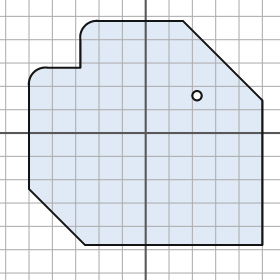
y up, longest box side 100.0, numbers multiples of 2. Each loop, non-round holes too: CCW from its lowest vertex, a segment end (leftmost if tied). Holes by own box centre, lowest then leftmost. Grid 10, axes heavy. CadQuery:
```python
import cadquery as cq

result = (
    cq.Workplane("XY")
    .moveTo(-26.0, -48.0)
    .lineTo(50.0, -48.0)
    .lineTo(50.0, 14.0)
    .lineTo(16.0, 48.0)
    .lineTo(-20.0, 48.0)
    .threePointArc((-26.0, 46.0), (-28.0, 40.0))
    .lineTo(-28.0, 28.0)
    .lineTo(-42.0, 28.0)
    .threePointArc((-48.0, 26.0), (-50.0, 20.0))
    .lineTo(-50.0, -24.0)
    .close()
    .moveTo(22.0, 16.0)
    .circle(2.0)
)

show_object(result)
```